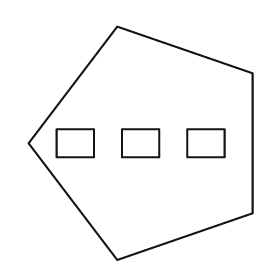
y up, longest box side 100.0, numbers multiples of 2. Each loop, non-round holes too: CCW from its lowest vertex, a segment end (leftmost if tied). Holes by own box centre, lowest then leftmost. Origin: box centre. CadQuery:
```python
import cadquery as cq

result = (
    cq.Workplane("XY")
    .moveTo(-10.0, -50.0)
    .lineTo(48.0, -30.0)
    .lineTo(48.0, 30.0)
    .lineTo(-10.0, 50.0)
    .lineTo(-48.0, 0.0)
    .close()
    .moveTo(-36.0, -6.0)
    .lineTo(-20.0, -6.0)
    .lineTo(-20.0, 6.0)
    .lineTo(-36.0, 6.0)
    .close()
    .moveTo(-8.0, -6.0)
    .lineTo(8.0, -6.0)
    .lineTo(8.0, 6.0)
    .lineTo(-8.0, 6.0)
    .close()
    .moveTo(20.0, -6.0)
    .lineTo(36.0, -6.0)
    .lineTo(36.0, 6.0)
    .lineTo(20.0, 6.0)
    .close()
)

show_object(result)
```